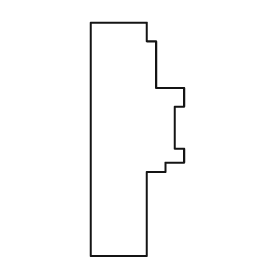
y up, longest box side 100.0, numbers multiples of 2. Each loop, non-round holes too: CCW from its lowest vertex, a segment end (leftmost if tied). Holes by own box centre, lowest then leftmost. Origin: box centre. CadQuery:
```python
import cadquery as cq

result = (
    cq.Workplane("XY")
    .moveTo(-20.0, -50.0)
    .lineTo(4.0, -50.0)
    .lineTo(4.0, -14.0)
    .lineTo(12.0, -14.0)
    .lineTo(12.0, -10.0)
    .lineTo(20.0, -10.0)
    .lineTo(20.0, -4.0)
    .lineTo(16.0, -4.0)
    .lineTo(16.0, 14.0)
    .lineTo(20.0, 14.0)
    .lineTo(20.0, 22.0)
    .lineTo(8.0, 22.0)
    .lineTo(8.0, 42.0)
    .lineTo(4.0, 42.0)
    .lineTo(4.0, 50.0)
    .lineTo(-20.0, 50.0)
    .close()
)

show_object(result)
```